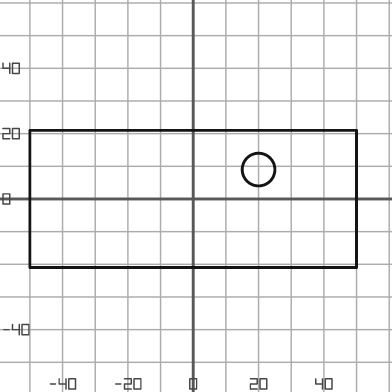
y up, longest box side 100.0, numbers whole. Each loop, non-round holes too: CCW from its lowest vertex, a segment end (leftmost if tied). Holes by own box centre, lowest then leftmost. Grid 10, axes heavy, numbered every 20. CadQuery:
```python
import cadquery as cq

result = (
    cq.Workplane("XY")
    .moveTo(-50.0, -21.0)
    .lineTo(50.0, -21.0)
    .lineTo(50.0, 21.0)
    .lineTo(-50.0, 21.0)
    .close()
    .moveTo(20.0, 9.0)
    .circle(5.0)
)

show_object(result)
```